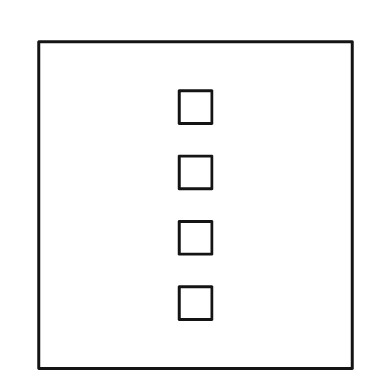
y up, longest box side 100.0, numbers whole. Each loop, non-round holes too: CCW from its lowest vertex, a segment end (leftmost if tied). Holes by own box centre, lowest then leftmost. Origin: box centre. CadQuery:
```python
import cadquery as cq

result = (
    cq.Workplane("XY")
    .moveTo(-48.0, -50.0)
    .lineTo(48.0, -50.0)
    .lineTo(48.0, 50.0)
    .lineTo(-48.0, 50.0)
    .close()
    .moveTo(-5.0, -35.0)
    .lineTo(5.0, -35.0)
    .lineTo(5.0, -25.0)
    .lineTo(-5.0, -25.0)
    .close()
    .moveTo(-5.0, -15.0)
    .lineTo(5.0, -15.0)
    .lineTo(5.0, -5.0)
    .lineTo(-5.0, -5.0)
    .close()
    .moveTo(-5.0, 5.0)
    .lineTo(5.0, 5.0)
    .lineTo(5.0, 15.0)
    .lineTo(-5.0, 15.0)
    .close()
    .moveTo(-5.0, 25.0)
    .lineTo(5.0, 25.0)
    .lineTo(5.0, 35.0)
    .lineTo(-5.0, 35.0)
    .close()
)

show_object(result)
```